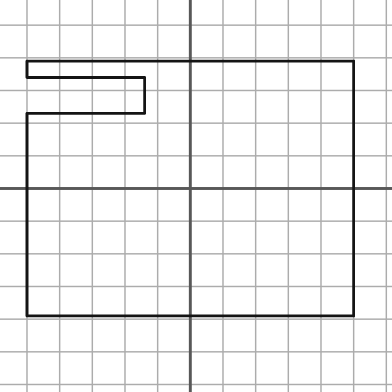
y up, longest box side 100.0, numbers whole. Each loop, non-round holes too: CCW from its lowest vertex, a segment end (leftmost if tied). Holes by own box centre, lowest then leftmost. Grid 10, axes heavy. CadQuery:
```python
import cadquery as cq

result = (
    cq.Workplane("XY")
    .moveTo(-50.0, -39.0)
    .lineTo(50.0, -39.0)
    .lineTo(50.0, 39.0)
    .lineTo(-50.0, 39.0)
    .lineTo(-50.0, 34.0)
    .lineTo(-14.0, 34.0)
    .lineTo(-14.0, 23.0)
    .lineTo(-50.0, 23.0)
    .close()
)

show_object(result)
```